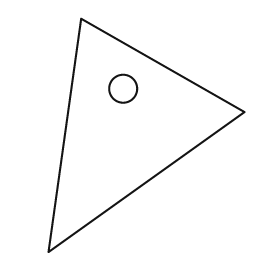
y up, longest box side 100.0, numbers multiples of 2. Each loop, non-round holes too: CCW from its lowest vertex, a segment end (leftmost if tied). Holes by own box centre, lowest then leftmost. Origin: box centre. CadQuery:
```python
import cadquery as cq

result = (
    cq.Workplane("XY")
    .moveTo(-42.0, -50.0)
    .lineTo(42.0, 10.0)
    .lineTo(-28.0, 50.0)
    .close()
    .moveTo(-10.0, 20.0)
    .circle(6.0)
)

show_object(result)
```